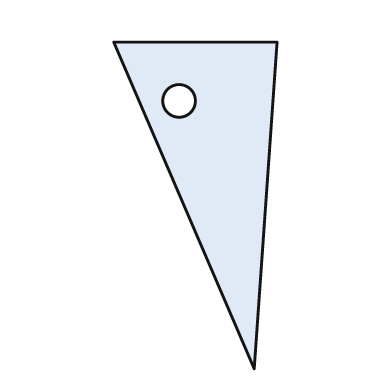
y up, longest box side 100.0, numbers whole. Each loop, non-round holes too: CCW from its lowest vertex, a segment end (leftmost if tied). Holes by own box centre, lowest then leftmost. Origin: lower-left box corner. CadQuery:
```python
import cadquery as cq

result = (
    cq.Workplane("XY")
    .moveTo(43.0, 0.0)
    .lineTo(50.0, 100.0)
    .lineTo(0.0, 100.0)
    .close()
    .moveTo(20.0, 82.0)
    .circle(5.0)
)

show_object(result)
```